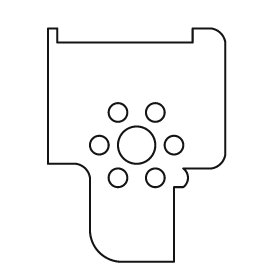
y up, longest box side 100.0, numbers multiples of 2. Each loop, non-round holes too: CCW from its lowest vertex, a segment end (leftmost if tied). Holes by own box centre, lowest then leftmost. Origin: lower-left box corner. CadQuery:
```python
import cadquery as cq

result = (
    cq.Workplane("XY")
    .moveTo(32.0, 0.0)
    .lineTo(54.0, 0.0)
    .lineTo(54.0, 32.0)
    .lineTo(58.0, 32.0)
    .threePointArc((60.0, 36.0), (58.0, 40.0))
    .lineTo(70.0, 40.0)
    .threePointArc((74.0, 42.0), (76.0, 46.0))
    .lineTo(76.0, 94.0)
    .threePointArc((74.0, 98.0), (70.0, 100.0))
    .lineTo(62.0, 100.0)
    .lineTo(62.0, 94.0)
    .lineTo(4.0, 94.0)
    .lineTo(4.0, 100.0)
    .lineTo(0.0, 100.0)
    .lineTo(0.0, 42.0)
    .lineTo(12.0, 42.0)
    .threePointArc((16.0, 40.0), (18.0, 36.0))
    .lineTo(18.0, 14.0)
    .threePointArc((22.0, 4.0), (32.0, 0.0))
    .close()
    .moveTo(30.0, 36.0)
    .circle(4.0)
    .moveTo(46.0, 36.0)
    .circle(4.0)
    .moveTo(22.0, 50.0)
    .circle(4.0)
    .moveTo(38.0, 50.0)
    .circle(8.0)
    .moveTo(54.0, 50.0)
    .circle(4.0)
    .moveTo(30.0, 64.0)
    .circle(4.0)
    .moveTo(46.0, 64.0)
    .circle(4.0)
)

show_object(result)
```